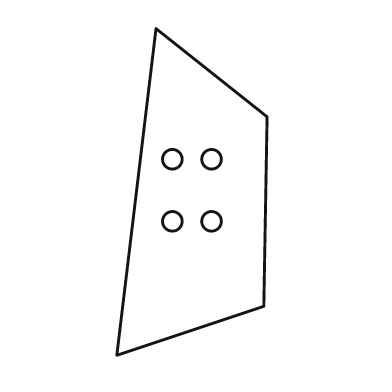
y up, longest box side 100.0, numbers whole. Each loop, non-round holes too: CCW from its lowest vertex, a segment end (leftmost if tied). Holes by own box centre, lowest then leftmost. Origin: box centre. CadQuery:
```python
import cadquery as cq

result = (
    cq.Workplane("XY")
    .moveTo(-23.0, -50.0)
    .lineTo(22.0, -35.0)
    .lineTo(23.0, 23.0)
    .lineTo(-11.0, 50.0)
    .close()
    .moveTo(-6.0, -9.0)
    .circle(3.0)
    .moveTo(6.0, -9.0)
    .circle(3.0)
    .moveTo(-6.0, 10.0)
    .circle(3.0)
    .moveTo(6.0, 10.0)
    .circle(3.0)
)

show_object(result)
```